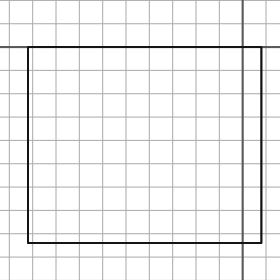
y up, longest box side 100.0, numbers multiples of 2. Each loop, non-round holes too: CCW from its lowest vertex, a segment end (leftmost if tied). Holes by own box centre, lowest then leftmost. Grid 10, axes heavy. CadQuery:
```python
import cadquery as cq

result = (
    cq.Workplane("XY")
    .moveTo(-92.0, -84.0)
    .lineTo(8.0, -84.0)
    .lineTo(8.0, 0.0)
    .lineTo(-92.0, 0.0)
    .close()
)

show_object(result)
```